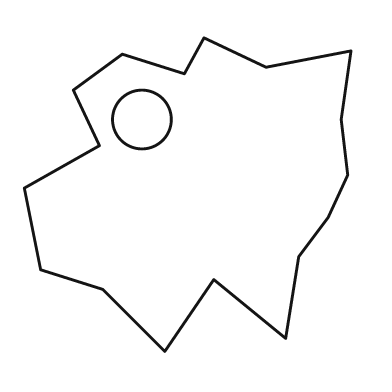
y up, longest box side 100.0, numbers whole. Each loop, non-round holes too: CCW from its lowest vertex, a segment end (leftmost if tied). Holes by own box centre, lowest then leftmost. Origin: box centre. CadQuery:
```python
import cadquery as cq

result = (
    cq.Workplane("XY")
    .moveTo(-7.0, -48.0)
    .lineTo(8.0, -26.0)
    .lineTo(30.0, -44.0)
    .lineTo(34.0, -19.0)
    .lineTo(43.0, -7.0)
    .lineTo(49.0, 6.0)
    .lineTo(47.0, 23.0)
    .lineTo(50.0, 44.0)
    .lineTo(24.0, 39.0)
    .lineTo(5.0, 48.0)
    .lineTo(-1.0, 37.0)
    .lineTo(-20.0, 43.0)
    .lineTo(-35.0, 32.0)
    .lineTo(-27.0, 15.0)
    .lineTo(-50.0, 2.0)
    .lineTo(-45.0, -23.0)
    .lineTo(-26.0, -29.0)
    .close()
    .moveTo(-14.0, 23.0)
    .circle(9.0)
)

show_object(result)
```